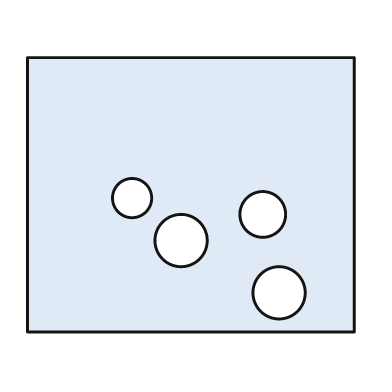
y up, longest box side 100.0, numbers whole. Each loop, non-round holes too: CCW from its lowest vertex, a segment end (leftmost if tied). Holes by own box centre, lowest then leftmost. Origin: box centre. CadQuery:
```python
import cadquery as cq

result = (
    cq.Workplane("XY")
    .moveTo(-50.0, -42.0)
    .lineTo(50.0, -42.0)
    .lineTo(50.0, 42.0)
    .lineTo(-50.0, 42.0)
    .close()
    .moveTo(27.0, -30.0)
    .circle(8.0)
    .moveTo(-3.0, -14.0)
    .circle(8.0)
    .moveTo(22.0, -6.0)
    .circle(7.0)
    .moveTo(-18.0, -1.0)
    .circle(6.0)
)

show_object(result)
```